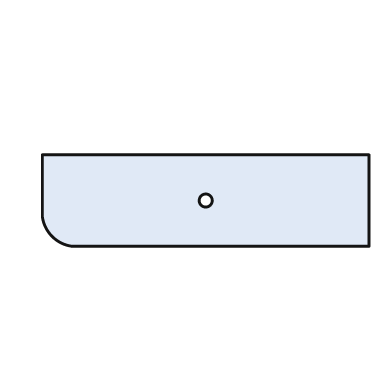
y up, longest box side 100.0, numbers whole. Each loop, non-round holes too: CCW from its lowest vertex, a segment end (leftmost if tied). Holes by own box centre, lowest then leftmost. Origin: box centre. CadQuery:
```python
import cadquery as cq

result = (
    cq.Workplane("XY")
    .moveTo(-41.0, -14.0)
    .lineTo(50.0, -14.0)
    .lineTo(50.0, 14.0)
    .lineTo(-50.0, 14.0)
    .lineTo(-50.0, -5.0)
    .threePointArc((-47.0, -11.0), (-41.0, -14.0))
    .close()
    .moveTo(0.0, 0.0)
    .circle(2.0)
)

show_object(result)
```